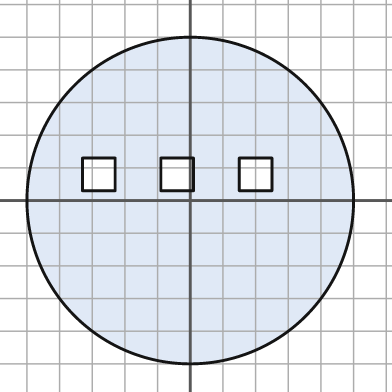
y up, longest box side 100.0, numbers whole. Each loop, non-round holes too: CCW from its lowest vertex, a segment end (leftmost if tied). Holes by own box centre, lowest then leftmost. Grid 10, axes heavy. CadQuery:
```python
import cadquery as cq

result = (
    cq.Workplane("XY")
    .moveTo(0.0, 0.0)
    .circle(50.0)
    .moveTo(-33.0, 3.0)
    .lineTo(-23.0, 3.0)
    .lineTo(-23.0, 13.0)
    .lineTo(-33.0, 13.0)
    .close()
    .moveTo(-9.0, 3.0)
    .lineTo(1.0, 3.0)
    .lineTo(1.0, 13.0)
    .lineTo(-9.0, 13.0)
    .close()
    .moveTo(15.0, 3.0)
    .lineTo(25.0, 3.0)
    .lineTo(25.0, 13.0)
    .lineTo(15.0, 13.0)
    .close()
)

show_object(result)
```